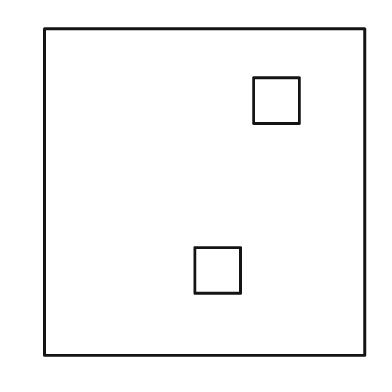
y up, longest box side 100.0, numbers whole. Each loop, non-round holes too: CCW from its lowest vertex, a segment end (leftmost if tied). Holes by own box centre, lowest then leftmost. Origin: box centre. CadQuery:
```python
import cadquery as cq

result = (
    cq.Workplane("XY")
    .moveTo(-49.0, -50.0)
    .lineTo(49.0, -50.0)
    .lineTo(49.0, 50.0)
    .lineTo(-49.0, 50.0)
    .close()
    .moveTo(-3.0, -31.0)
    .lineTo(11.0, -31.0)
    .lineTo(11.0, -17.0)
    .lineTo(-3.0, -17.0)
    .close()
    .moveTo(15.0, 21.0)
    .lineTo(29.0, 21.0)
    .lineTo(29.0, 35.0)
    .lineTo(15.0, 35.0)
    .close()
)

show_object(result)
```